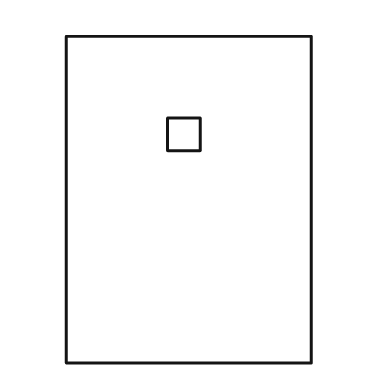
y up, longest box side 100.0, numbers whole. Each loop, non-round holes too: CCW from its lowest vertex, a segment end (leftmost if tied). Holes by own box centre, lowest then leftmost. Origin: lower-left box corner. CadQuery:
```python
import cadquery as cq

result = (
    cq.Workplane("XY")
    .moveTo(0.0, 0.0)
    .lineTo(75.0, 0.0)
    .lineTo(75.0, 100.0)
    .lineTo(0.0, 100.0)
    .close()
    .moveTo(31.0, 65.0)
    .lineTo(41.0, 65.0)
    .lineTo(41.0, 75.0)
    .lineTo(31.0, 75.0)
    .close()
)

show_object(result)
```